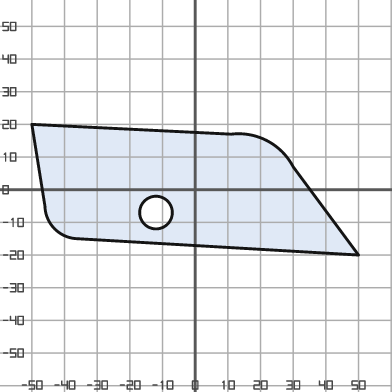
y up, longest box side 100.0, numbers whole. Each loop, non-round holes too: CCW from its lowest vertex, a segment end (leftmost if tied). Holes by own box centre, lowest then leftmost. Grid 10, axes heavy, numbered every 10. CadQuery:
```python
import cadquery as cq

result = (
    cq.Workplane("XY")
    .moveTo(50.0, -20.0)
    .lineTo(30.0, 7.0)
    .threePointArc((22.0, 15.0), (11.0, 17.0))
    .lineTo(-50.0, 20.0)
    .lineTo(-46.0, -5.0)
    .threePointArc((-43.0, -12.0), (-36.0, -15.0))
    .close()
    .moveTo(-12.0, -7.0)
    .circle(5.0)
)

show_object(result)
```